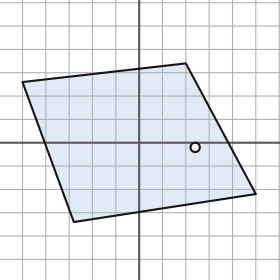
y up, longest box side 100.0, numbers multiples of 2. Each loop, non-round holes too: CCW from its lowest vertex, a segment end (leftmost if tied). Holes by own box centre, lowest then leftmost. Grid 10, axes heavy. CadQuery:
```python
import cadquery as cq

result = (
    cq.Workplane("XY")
    .moveTo(-28.0, -34.0)
    .lineTo(50.0, -22.0)
    .lineTo(20.0, 34.0)
    .lineTo(-50.0, 26.0)
    .close()
    .moveTo(24.0, -2.0)
    .circle(2.0)
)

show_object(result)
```